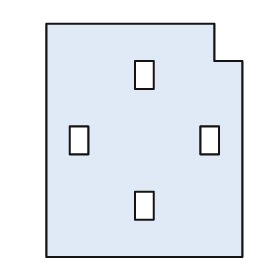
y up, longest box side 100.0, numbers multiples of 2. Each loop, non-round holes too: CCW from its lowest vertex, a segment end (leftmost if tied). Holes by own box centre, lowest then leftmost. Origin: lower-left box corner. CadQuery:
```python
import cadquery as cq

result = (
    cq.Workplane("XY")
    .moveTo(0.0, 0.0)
    .lineTo(84.0, 0.0)
    .lineTo(84.0, 84.0)
    .lineTo(72.0, 84.0)
    .lineTo(72.0, 100.0)
    .lineTo(0.0, 100.0)
    .close()
    .moveTo(38.0, 16.0)
    .lineTo(46.0, 16.0)
    .lineTo(46.0, 28.0)
    .lineTo(38.0, 28.0)
    .close()
    .moveTo(10.0, 44.0)
    .lineTo(18.0, 44.0)
    .lineTo(18.0, 56.0)
    .lineTo(10.0, 56.0)
    .close()
    .moveTo(66.0, 44.0)
    .lineTo(74.0, 44.0)
    .lineTo(74.0, 56.0)
    .lineTo(66.0, 56.0)
    .close()
    .moveTo(38.0, 72.0)
    .lineTo(46.0, 72.0)
    .lineTo(46.0, 84.0)
    .lineTo(38.0, 84.0)
    .close()
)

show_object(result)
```